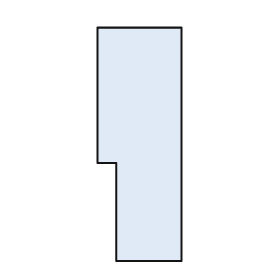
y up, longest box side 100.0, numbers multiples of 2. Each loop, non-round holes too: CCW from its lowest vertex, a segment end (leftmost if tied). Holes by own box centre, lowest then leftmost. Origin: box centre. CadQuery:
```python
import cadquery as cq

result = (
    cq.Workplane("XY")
    .moveTo(-10.0, -50.0)
    .lineTo(18.0, -50.0)
    .lineTo(18.0, 50.0)
    .lineTo(-18.0, 50.0)
    .lineTo(-18.0, -8.0)
    .lineTo(-10.0, -8.0)
    .close()
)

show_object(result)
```